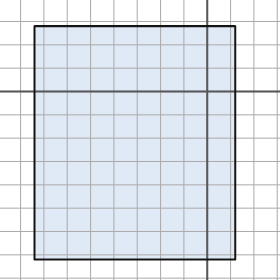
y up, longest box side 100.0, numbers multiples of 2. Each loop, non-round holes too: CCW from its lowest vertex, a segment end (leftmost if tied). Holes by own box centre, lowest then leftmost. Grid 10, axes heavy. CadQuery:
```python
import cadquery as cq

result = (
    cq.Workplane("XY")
    .moveTo(-74.0, -72.0)
    .lineTo(12.0, -72.0)
    .lineTo(12.0, 28.0)
    .lineTo(-74.0, 28.0)
    .close()
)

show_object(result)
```